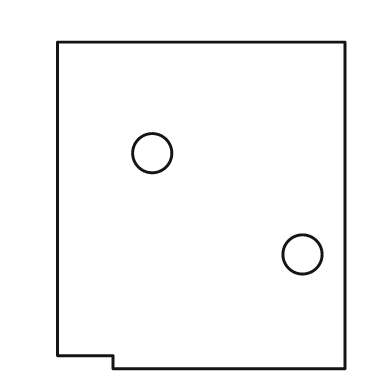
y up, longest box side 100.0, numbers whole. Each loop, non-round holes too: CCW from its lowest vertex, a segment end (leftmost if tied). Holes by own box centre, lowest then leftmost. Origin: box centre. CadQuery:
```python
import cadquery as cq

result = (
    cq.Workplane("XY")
    .moveTo(-27.0, -50.0)
    .lineTo(44.0, -50.0)
    .lineTo(44.0, 50.0)
    .lineTo(-44.0, 50.0)
    .lineTo(-44.0, -46.0)
    .lineTo(-27.0, -46.0)
    .close()
    .moveTo(31.0, -15.0)
    .circle(6.0)
    .moveTo(-15.0, 16.0)
    .circle(6.0)
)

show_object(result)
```